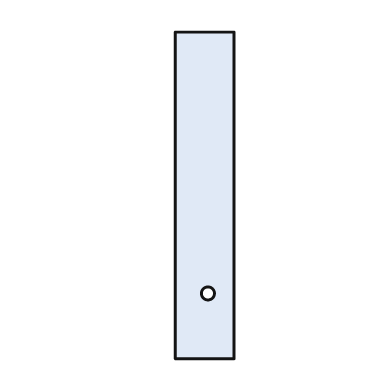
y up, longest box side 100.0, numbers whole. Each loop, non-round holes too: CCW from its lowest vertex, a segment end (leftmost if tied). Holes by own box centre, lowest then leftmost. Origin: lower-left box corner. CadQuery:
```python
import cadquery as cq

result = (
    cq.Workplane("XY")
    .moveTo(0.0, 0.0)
    .lineTo(18.0, 0.0)
    .lineTo(18.0, 100.0)
    .lineTo(0.0, 100.0)
    .close()
    .moveTo(10.0, 20.0)
    .circle(2.0)
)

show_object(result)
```